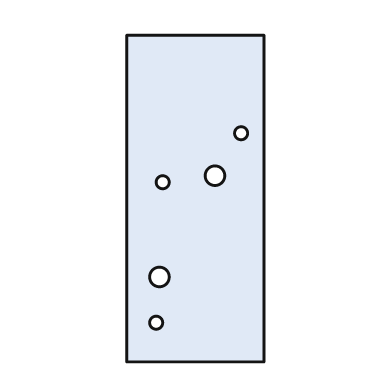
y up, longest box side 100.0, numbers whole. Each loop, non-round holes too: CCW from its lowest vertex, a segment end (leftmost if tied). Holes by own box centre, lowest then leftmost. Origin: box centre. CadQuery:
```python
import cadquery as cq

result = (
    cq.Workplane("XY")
    .moveTo(-21.0, -50.0)
    .lineTo(21.0, -50.0)
    .lineTo(21.0, 50.0)
    .lineTo(-21.0, 50.0)
    .close()
    .moveTo(-12.0, -38.0)
    .circle(2.0)
    .moveTo(-11.0, -24.0)
    .circle(3.0)
    .moveTo(-10.0, 5.0)
    .circle(2.0)
    .moveTo(6.0, 7.0)
    .circle(3.0)
    .moveTo(14.0, 20.0)
    .circle(2.0)
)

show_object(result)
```